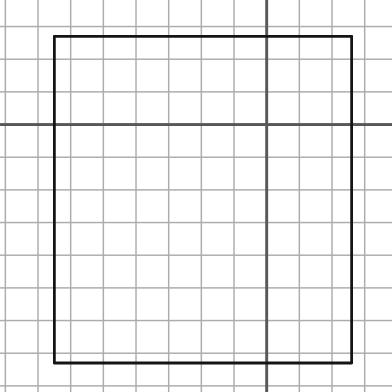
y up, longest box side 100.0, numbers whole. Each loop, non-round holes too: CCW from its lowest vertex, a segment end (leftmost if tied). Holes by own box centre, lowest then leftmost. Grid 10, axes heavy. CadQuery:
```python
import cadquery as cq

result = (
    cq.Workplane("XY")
    .moveTo(-65.0, -73.0)
    .lineTo(26.0, -73.0)
    .lineTo(26.0, 27.0)
    .lineTo(-65.0, 27.0)
    .close()
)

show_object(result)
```